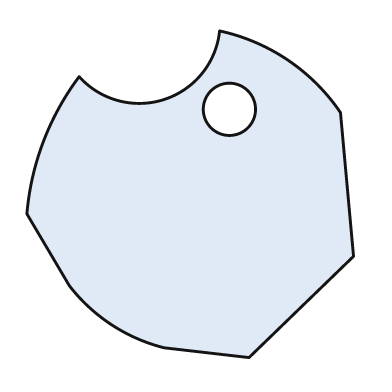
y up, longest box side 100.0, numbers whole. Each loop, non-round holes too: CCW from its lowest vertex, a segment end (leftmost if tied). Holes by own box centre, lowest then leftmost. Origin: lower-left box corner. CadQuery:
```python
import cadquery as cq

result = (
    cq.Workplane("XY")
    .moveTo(68.0, 0.0)
    .lineTo(100.0, 31.0)
    .lineTo(96.0, 75.0)
    .threePointArc((80.0, 91.0), (59.0, 100.0))
    .threePointArc((42.0, 79.0), (16.0, 86.0))
    .threePointArc((5.0, 66.0), (0.0, 44.0))
    .lineTo(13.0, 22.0)
    .threePointArc((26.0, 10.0), (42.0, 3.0))
    .close()
    .moveTo(62.0, 76.0)
    .circle(8.0)
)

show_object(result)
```